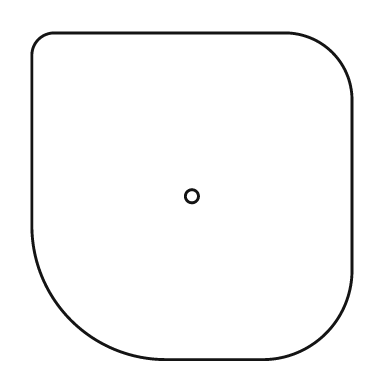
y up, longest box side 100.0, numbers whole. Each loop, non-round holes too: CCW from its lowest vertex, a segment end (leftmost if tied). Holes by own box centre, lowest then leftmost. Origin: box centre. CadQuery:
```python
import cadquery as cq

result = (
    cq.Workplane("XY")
    .moveTo(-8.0, -50.0)
    .lineTo(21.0, -50.0)
    .threePointArc((41.0, -42.0), (49.0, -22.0))
    .lineTo(49.0, 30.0)
    .threePointArc((43.0, 44.0), (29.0, 50.0))
    .lineTo(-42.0, 50.0)
    .threePointArc((-47.0, 48.0), (-49.0, 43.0))
    .lineTo(-49.0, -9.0)
    .threePointArc((-37.0, -38.0), (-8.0, -50.0))
    .close()
    .moveTo(0.0, 0.0)
    .circle(2.0)
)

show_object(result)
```